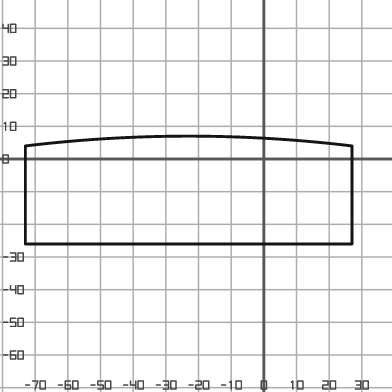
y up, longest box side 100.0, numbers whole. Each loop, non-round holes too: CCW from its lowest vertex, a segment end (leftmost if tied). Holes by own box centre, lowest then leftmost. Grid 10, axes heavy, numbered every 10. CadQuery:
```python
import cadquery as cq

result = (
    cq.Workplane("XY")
    .moveTo(-73.0, -26.0)
    .lineTo(27.0, -26.0)
    .lineTo(27.0, 4.0)
    .threePointArc((-23.0, 7.0), (-73.0, 4.0))
    .close()
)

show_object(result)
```